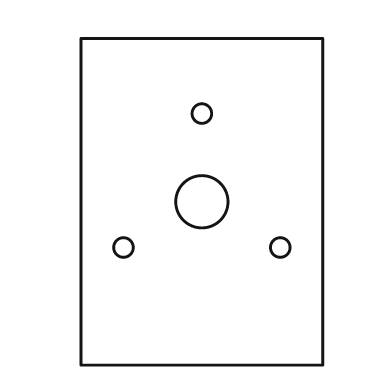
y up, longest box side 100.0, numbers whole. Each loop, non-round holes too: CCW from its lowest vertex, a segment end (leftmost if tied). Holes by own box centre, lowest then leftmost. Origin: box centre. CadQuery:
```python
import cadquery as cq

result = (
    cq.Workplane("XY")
    .moveTo(-37.0, -50.0)
    .lineTo(37.0, -50.0)
    .lineTo(37.0, 50.0)
    .lineTo(-37.0, 50.0)
    .close()
    .moveTo(-24.0, -14.0)
    .circle(3.0)
    .moveTo(24.0, -14.0)
    .circle(3.0)
    .moveTo(0.0, 0.0)
    .circle(8.0)
    .moveTo(0.0, 27.0)
    .circle(3.0)
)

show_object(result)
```